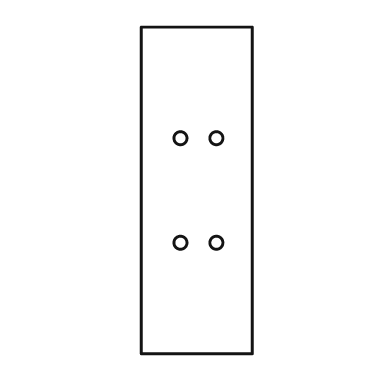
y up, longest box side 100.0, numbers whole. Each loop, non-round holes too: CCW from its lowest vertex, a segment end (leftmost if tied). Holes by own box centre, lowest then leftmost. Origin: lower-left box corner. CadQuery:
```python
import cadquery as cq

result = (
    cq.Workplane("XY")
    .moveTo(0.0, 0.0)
    .lineTo(34.0, 0.0)
    .lineTo(34.0, 100.0)
    .lineTo(0.0, 100.0)
    .close()
    .moveTo(12.0, 34.0)
    .circle(2.0)
    .moveTo(23.0, 34.0)
    .circle(2.0)
    .moveTo(12.0, 66.0)
    .circle(2.0)
    .moveTo(23.0, 66.0)
    .circle(2.0)
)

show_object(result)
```